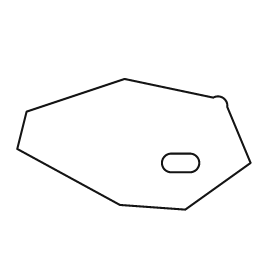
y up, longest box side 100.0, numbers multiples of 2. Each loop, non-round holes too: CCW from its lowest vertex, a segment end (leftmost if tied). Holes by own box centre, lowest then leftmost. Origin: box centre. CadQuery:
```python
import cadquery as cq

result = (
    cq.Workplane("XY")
    .moveTo(22.0, -28.0)
    .lineTo(50.0, -8.0)
    .lineTo(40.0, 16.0)
    .threePointArc((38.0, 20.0), (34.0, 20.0))
    .lineTo(-4.0, 28.0)
    .lineTo(-46.0, 14.0)
    .lineTo(-50.0, -2.0)
    .lineTo(-6.0, -26.0)
    .close()
    .moveTo(16.0, -12.0)
    .lineTo(24.0, -12.0)
    .threePointArc((28.0, -8.0), (24.0, -4.0))
    .lineTo(16.0, -4.0)
    .threePointArc((12.0, -8.0), (16.0, -12.0))
    .close()
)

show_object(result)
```